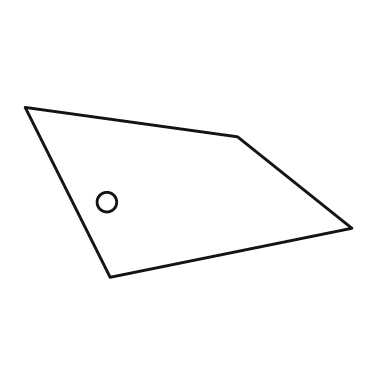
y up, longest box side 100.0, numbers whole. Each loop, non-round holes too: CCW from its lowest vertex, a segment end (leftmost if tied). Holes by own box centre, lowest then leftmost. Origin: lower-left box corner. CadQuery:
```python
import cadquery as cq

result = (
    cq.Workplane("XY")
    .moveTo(26.0, 0.0)
    .lineTo(100.0, 15.0)
    .lineTo(65.0, 43.0)
    .lineTo(0.0, 52.0)
    .close()
    .moveTo(25.0, 23.0)
    .circle(3.0)
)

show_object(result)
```